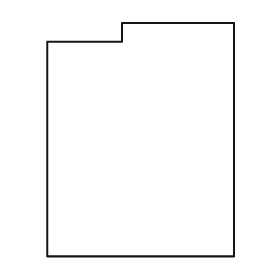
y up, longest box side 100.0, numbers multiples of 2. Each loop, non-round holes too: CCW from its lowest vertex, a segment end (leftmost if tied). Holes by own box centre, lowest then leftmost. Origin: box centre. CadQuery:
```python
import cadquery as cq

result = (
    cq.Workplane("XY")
    .moveTo(-40.0, -50.0)
    .lineTo(40.0, -50.0)
    .lineTo(40.0, 50.0)
    .lineTo(-8.0, 50.0)
    .lineTo(-8.0, 42.0)
    .lineTo(-40.0, 42.0)
    .close()
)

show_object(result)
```